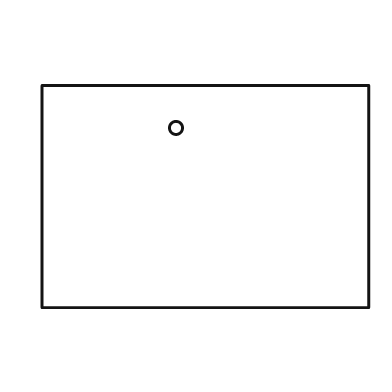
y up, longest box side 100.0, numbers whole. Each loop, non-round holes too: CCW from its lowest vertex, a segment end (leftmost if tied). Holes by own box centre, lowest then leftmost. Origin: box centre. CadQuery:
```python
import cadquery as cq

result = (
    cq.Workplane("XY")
    .moveTo(-50.0, -34.0)
    .lineTo(50.0, -34.0)
    .lineTo(50.0, 34.0)
    .lineTo(-50.0, 34.0)
    .close()
    .moveTo(-9.0, 21.0)
    .circle(2.0)
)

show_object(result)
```